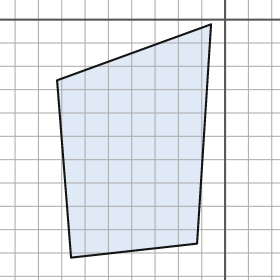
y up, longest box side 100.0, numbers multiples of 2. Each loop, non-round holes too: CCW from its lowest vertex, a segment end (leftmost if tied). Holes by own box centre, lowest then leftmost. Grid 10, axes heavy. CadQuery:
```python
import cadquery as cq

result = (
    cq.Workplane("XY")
    .moveTo(-66.0, -102.0)
    .lineTo(-12.0, -96.0)
    .lineTo(-6.0, -2.0)
    .lineTo(-72.0, -26.0)
    .close()
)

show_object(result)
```